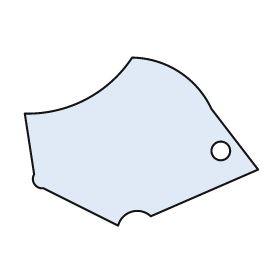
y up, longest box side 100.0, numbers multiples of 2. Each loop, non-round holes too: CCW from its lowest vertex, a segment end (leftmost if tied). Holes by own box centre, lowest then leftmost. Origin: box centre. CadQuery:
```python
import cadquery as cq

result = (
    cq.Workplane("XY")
    .moveTo(-10.0, -36.0)
    .threePointArc((-4.0, -30.0), (4.0, -32.0))
    .lineTo(50.0, -12.0)
    .lineTo(30.0, 14.0)
    .threePointArc((16.0, 30.0), (-4.0, 36.0))
    .threePointArc((-24.0, 18.0), (-50.0, 12.0))
    .lineTo(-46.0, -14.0)
    .threePointArc((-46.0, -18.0), (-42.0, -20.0))
    .close()
    .moveTo(34.0, -4.0)
    .circle(4.0)
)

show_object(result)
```